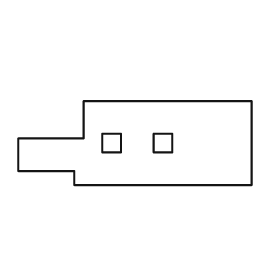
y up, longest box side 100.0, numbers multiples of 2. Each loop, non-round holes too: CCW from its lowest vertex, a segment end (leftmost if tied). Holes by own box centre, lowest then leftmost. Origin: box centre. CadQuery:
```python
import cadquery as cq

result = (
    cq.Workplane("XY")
    .moveTo(-26.0, -18.0)
    .lineTo(50.0, -18.0)
    .lineTo(50.0, 18.0)
    .lineTo(-22.0, 18.0)
    .lineTo(-22.0, 2.0)
    .lineTo(-50.0, 2.0)
    .lineTo(-50.0, -12.0)
    .lineTo(-26.0, -12.0)
    .close()
    .moveTo(-14.0, -4.0)
    .lineTo(-6.0, -4.0)
    .lineTo(-6.0, 4.0)
    .lineTo(-14.0, 4.0)
    .close()
    .moveTo(8.0, -4.0)
    .lineTo(16.0, -4.0)
    .lineTo(16.0, 4.0)
    .lineTo(8.0, 4.0)
    .close()
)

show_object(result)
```